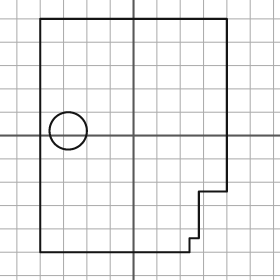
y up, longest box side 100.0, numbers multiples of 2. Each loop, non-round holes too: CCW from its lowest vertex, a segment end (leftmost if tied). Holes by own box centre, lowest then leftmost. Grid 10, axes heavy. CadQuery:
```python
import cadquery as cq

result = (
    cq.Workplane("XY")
    .moveTo(-40.0, -50.0)
    .lineTo(24.0, -50.0)
    .lineTo(24.0, -44.0)
    .lineTo(28.0, -44.0)
    .lineTo(28.0, -24.0)
    .lineTo(40.0, -24.0)
    .lineTo(40.0, 50.0)
    .lineTo(-40.0, 50.0)
    .close()
    .moveTo(-28.0, 2.0)
    .circle(8.0)
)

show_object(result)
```